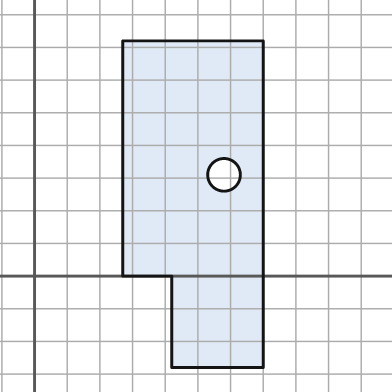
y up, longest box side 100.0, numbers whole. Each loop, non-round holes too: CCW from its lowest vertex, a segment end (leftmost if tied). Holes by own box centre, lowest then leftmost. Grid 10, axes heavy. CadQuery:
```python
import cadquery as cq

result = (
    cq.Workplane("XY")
    .moveTo(42.0, -28.0)
    .lineTo(70.0, -28.0)
    .lineTo(70.0, 72.0)
    .lineTo(27.0, 72.0)
    .lineTo(27.0, 0.0)
    .lineTo(42.0, 0.0)
    .close()
    .moveTo(58.0, 31.0)
    .circle(5.0)
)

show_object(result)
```